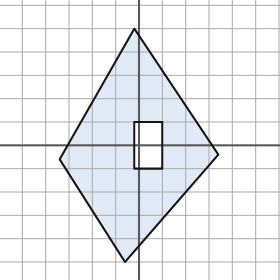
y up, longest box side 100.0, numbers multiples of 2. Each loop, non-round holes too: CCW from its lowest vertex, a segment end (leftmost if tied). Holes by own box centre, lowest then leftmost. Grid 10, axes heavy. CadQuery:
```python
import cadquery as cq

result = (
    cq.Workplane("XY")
    .moveTo(-6.0, -50.0)
    .lineTo(34.0, -4.0)
    .lineTo(-2.0, 50.0)
    .lineTo(-34.0, -6.0)
    .close()
    .moveTo(-2.0, -10.0)
    .lineTo(10.0, -10.0)
    .lineTo(10.0, 10.0)
    .lineTo(-2.0, 10.0)
    .close()
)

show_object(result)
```